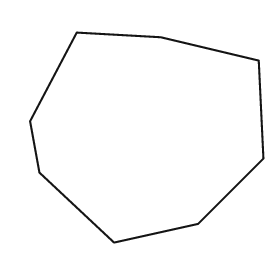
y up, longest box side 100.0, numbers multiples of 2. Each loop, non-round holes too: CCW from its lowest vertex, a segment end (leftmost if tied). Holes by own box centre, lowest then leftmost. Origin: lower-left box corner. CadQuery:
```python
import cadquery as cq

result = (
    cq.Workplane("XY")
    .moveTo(36.0, 0.0)
    .lineTo(72.0, 8.0)
    .lineTo(100.0, 36.0)
    .lineTo(98.0, 78.0)
    .lineTo(56.0, 88.0)
    .lineTo(20.0, 90.0)
    .lineTo(0.0, 52.0)
    .lineTo(4.0, 30.0)
    .close()
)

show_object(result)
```